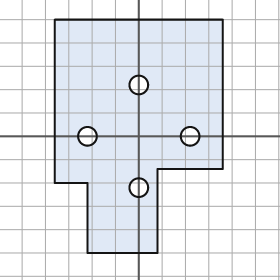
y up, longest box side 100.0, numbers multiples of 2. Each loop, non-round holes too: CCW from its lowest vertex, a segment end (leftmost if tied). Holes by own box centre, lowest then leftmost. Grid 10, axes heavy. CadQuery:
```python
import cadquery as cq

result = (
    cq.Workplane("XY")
    .moveTo(-22.0, -50.0)
    .lineTo(8.0, -50.0)
    .lineTo(8.0, -14.0)
    .lineTo(36.0, -14.0)
    .lineTo(36.0, 50.0)
    .lineTo(-36.0, 50.0)
    .lineTo(-36.0, -20.0)
    .lineTo(-22.0, -20.0)
    .close()
    .moveTo(0.0, -22.0)
    .circle(4.0)
    .moveTo(-22.0, 0.0)
    .circle(4.0)
    .moveTo(22.0, 0.0)
    .circle(4.0)
    .moveTo(0.0, 22.0)
    .circle(4.0)
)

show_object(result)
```